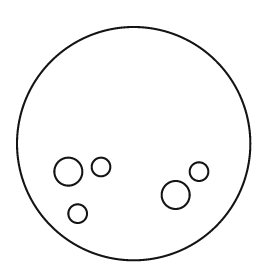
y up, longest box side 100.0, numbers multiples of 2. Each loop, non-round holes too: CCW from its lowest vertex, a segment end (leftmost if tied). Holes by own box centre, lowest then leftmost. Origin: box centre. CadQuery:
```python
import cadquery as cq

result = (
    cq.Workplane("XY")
    .moveTo(0.0, 0.0)
    .circle(50.0)
    .moveTo(-24.0, -30.0)
    .circle(4.0)
    .moveTo(18.0, -22.0)
    .circle(6.0)
    .moveTo(-28.0, -12.0)
    .circle(6.0)
    .moveTo(28.0, -12.0)
    .circle(4.0)
    .moveTo(-14.0, -10.0)
    .circle(4.0)
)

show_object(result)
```